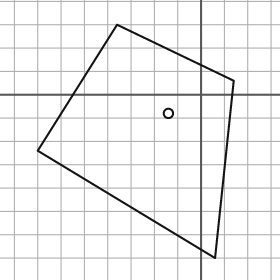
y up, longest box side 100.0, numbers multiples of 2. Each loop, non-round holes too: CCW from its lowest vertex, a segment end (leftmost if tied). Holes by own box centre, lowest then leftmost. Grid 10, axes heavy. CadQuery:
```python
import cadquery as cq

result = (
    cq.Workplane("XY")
    .moveTo(6.0, -70.0)
    .lineTo(14.0, 6.0)
    .lineTo(-36.0, 30.0)
    .lineTo(-70.0, -24.0)
    .close()
    .moveTo(-14.0, -8.0)
    .circle(2.0)
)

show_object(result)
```